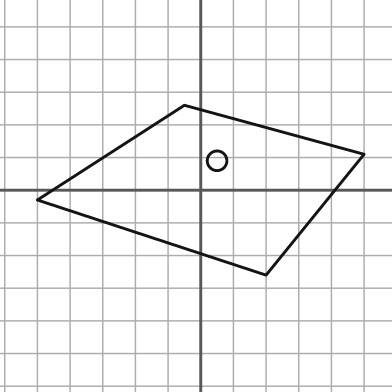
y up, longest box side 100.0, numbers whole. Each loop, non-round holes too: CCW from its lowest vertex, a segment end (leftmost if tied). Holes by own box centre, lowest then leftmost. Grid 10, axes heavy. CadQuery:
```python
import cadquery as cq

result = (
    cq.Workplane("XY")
    .moveTo(20.0, -26.0)
    .lineTo(50.0, 11.0)
    .lineTo(-5.0, 26.0)
    .lineTo(-50.0, -3.0)
    .close()
    .moveTo(5.0, 9.0)
    .circle(3.0)
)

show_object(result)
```